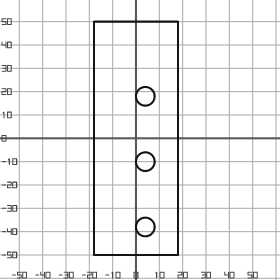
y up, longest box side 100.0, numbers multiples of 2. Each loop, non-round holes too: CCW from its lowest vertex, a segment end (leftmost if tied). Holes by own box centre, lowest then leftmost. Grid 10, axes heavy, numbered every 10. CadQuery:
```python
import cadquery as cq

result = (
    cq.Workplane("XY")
    .moveTo(-18.0, -50.0)
    .lineTo(18.0, -50.0)
    .lineTo(18.0, 50.0)
    .lineTo(-18.0, 50.0)
    .close()
    .moveTo(4.0, -38.0)
    .circle(4.0)
    .moveTo(4.0, -10.0)
    .circle(4.0)
    .moveTo(4.0, 18.0)
    .circle(4.0)
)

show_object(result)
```